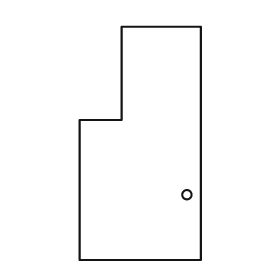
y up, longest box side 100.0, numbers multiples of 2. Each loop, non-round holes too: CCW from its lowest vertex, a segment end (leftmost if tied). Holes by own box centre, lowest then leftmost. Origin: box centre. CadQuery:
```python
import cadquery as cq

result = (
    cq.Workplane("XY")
    .moveTo(-26.0, -50.0)
    .lineTo(26.0, -50.0)
    .lineTo(26.0, 50.0)
    .lineTo(-8.0, 50.0)
    .lineTo(-8.0, 10.0)
    .lineTo(-26.0, 10.0)
    .close()
    .moveTo(20.0, -22.0)
    .circle(2.0)
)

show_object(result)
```